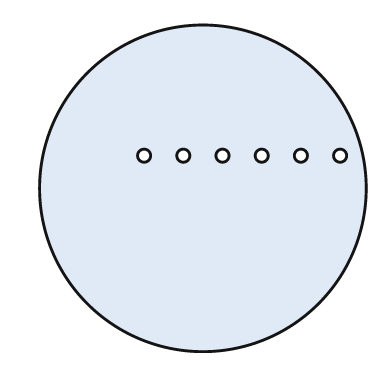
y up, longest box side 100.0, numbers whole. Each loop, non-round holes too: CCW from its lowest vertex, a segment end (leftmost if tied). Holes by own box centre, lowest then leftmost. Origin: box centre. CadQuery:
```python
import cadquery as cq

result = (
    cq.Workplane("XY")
    .moveTo(0.0, 0.0)
    .circle(50.0)
    .moveTo(-18.0, 10.0)
    .circle(2.0)
    .moveTo(-6.0, 10.0)
    .circle(2.0)
    .moveTo(6.0, 10.0)
    .circle(2.0)
    .moveTo(18.0, 10.0)
    .circle(2.0)
    .moveTo(30.0, 10.0)
    .circle(2.0)
    .moveTo(42.0, 10.0)
    .circle(2.0)
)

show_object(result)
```